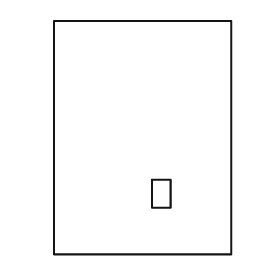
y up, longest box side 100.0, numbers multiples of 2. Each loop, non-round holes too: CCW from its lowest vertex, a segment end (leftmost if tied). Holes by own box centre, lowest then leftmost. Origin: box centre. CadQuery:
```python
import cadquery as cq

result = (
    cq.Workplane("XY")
    .moveTo(-38.0, -50.0)
    .lineTo(38.0, -50.0)
    .lineTo(38.0, 50.0)
    .lineTo(-38.0, 50.0)
    .close()
    .moveTo(4.0, -30.0)
    .lineTo(12.0, -30.0)
    .lineTo(12.0, -18.0)
    .lineTo(4.0, -18.0)
    .close()
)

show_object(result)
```